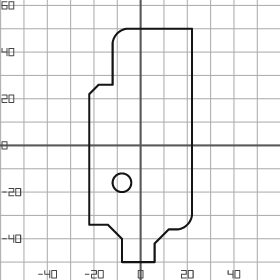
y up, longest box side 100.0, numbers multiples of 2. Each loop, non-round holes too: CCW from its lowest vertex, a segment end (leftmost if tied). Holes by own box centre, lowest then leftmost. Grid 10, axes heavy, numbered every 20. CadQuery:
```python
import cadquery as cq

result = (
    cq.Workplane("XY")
    .moveTo(-8.0, -50.0)
    .lineTo(6.0, -50.0)
    .lineTo(6.0, -42.0)
    .lineTo(12.0, -36.0)
    .lineTo(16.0, -36.0)
    .threePointArc((20.0, -34.0), (22.0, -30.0))
    .lineTo(22.0, 50.0)
    .lineTo(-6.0, 50.0)
    .threePointArc((-10.0, 48.0), (-12.0, 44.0))
    .lineTo(-12.0, 26.0)
    .lineTo(-18.0, 26.0)
    .lineTo(-22.0, 22.0)
    .lineTo(-22.0, -34.0)
    .lineTo(-14.0, -34.0)
    .lineTo(-8.0, -40.0)
    .close()
    .moveTo(-8.0, -16.0)
    .circle(4.0)
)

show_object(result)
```